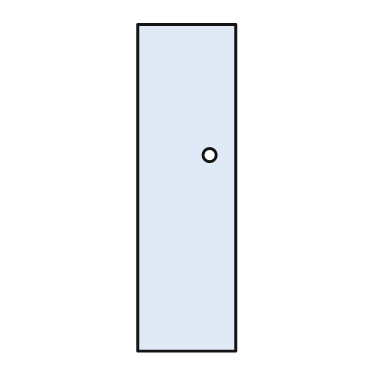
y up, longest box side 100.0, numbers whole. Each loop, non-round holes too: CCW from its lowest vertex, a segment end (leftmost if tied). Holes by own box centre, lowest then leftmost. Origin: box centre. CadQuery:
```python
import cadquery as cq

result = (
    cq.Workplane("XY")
    .moveTo(-15.0, -50.0)
    .lineTo(15.0, -50.0)
    .lineTo(15.0, 50.0)
    .lineTo(-15.0, 50.0)
    .close()
    .moveTo(7.0, 10.0)
    .circle(2.0)
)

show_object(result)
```